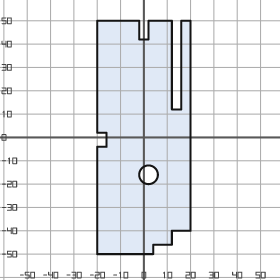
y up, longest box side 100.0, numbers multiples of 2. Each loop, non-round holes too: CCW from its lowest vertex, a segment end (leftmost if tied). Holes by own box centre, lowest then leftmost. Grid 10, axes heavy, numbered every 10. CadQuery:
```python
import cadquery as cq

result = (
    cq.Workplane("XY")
    .moveTo(-20.0, -50.0)
    .lineTo(4.0, -50.0)
    .lineTo(4.0, -46.0)
    .lineTo(12.0, -46.0)
    .lineTo(12.0, -40.0)
    .lineTo(20.0, -40.0)
    .lineTo(20.0, 50.0)
    .lineTo(16.0, 50.0)
    .lineTo(16.0, 12.0)
    .lineTo(12.0, 12.0)
    .lineTo(12.0, 50.0)
    .lineTo(2.0, 50.0)
    .lineTo(2.0, 42.0)
    .lineTo(-2.0, 42.0)
    .lineTo(-2.0, 50.0)
    .lineTo(-20.0, 50.0)
    .lineTo(-20.0, 2.0)
    .lineTo(-16.0, 2.0)
    .lineTo(-16.0, -4.0)
    .lineTo(-20.0, -4.0)
    .close()
    .moveTo(2.0, -16.0)
    .circle(4.0)
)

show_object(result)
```